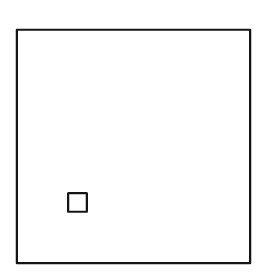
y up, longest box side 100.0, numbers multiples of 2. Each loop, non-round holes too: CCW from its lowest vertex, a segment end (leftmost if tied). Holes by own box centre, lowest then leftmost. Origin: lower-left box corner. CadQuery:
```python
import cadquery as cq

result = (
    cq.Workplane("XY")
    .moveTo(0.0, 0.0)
    .lineTo(100.0, 0.0)
    .lineTo(100.0, 100.0)
    .lineTo(0.0, 100.0)
    .close()
    .moveTo(22.0, 22.0)
    .lineTo(30.0, 22.0)
    .lineTo(30.0, 30.0)
    .lineTo(22.0, 30.0)
    .close()
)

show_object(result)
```